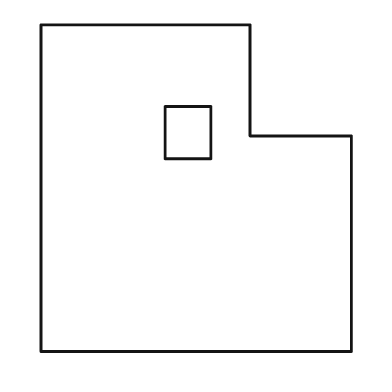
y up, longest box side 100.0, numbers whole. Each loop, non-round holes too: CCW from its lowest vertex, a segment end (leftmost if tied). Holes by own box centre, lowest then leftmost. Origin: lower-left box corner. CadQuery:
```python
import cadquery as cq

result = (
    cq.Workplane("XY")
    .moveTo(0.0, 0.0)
    .lineTo(95.0, 0.0)
    .lineTo(95.0, 66.0)
    .lineTo(64.0, 66.0)
    .lineTo(64.0, 100.0)
    .lineTo(0.0, 100.0)
    .close()
    .moveTo(38.0, 59.0)
    .lineTo(52.0, 59.0)
    .lineTo(52.0, 75.0)
    .lineTo(38.0, 75.0)
    .close()
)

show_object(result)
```